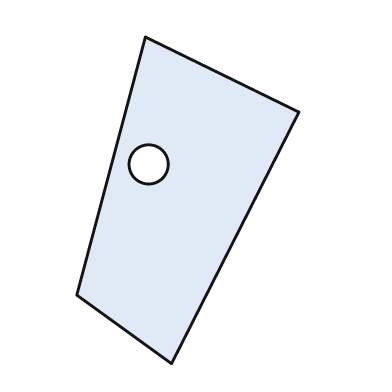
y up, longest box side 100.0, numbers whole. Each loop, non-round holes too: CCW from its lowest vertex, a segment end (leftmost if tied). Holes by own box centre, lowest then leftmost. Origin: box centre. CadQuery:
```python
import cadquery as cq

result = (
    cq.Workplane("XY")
    .moveTo(-5.0, -50.0)
    .lineTo(34.0, 27.0)
    .lineTo(-13.0, 50.0)
    .lineTo(-34.0, -29.0)
    .close()
    .moveTo(-12.0, 11.0)
    .circle(6.0)
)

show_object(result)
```